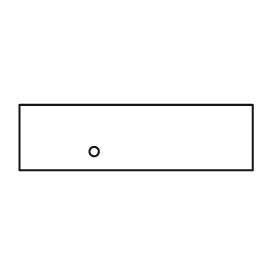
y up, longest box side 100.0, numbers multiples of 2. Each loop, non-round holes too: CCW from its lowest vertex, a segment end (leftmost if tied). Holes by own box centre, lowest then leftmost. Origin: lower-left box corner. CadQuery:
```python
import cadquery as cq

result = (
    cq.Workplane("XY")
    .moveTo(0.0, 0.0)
    .lineTo(100.0, 0.0)
    .lineTo(100.0, 28.0)
    .lineTo(0.0, 28.0)
    .close()
    .moveTo(32.0, 8.0)
    .circle(2.0)
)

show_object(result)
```